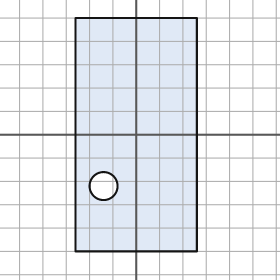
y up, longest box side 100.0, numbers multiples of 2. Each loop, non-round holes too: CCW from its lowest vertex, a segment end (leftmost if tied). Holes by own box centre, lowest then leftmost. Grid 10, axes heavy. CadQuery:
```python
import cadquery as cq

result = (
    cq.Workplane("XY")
    .moveTo(-26.0, -50.0)
    .lineTo(26.0, -50.0)
    .lineTo(26.0, 50.0)
    .lineTo(-26.0, 50.0)
    .close()
    .moveTo(-14.0, -22.0)
    .circle(6.0)
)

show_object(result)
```